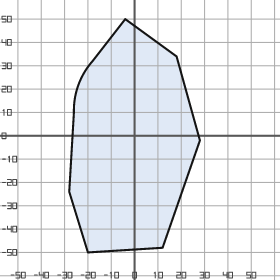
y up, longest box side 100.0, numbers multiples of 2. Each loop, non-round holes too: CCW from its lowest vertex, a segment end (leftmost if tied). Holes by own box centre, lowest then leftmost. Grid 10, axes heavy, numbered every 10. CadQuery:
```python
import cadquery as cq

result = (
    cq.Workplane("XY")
    .moveTo(-20.0, -50.0)
    .lineTo(12.0, -48.0)
    .lineTo(28.0, -2.0)
    .lineTo(18.0, 34.0)
    .lineTo(-4.0, 50.0)
    .lineTo(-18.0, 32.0)
    .threePointArc((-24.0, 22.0), (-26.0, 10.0))
    .lineTo(-28.0, -24.0)
    .close()
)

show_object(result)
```